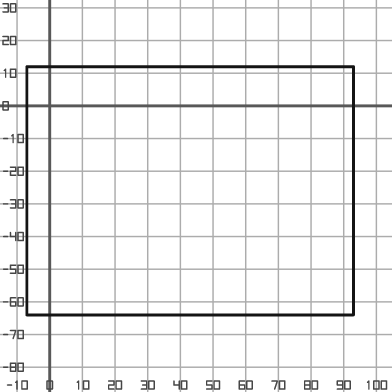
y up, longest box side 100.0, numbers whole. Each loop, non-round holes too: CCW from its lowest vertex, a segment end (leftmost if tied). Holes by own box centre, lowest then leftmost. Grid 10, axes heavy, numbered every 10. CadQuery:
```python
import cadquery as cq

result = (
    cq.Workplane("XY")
    .moveTo(-7.0, -64.0)
    .lineTo(93.0, -64.0)
    .lineTo(93.0, 12.0)
    .lineTo(-7.0, 12.0)
    .close()
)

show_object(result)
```